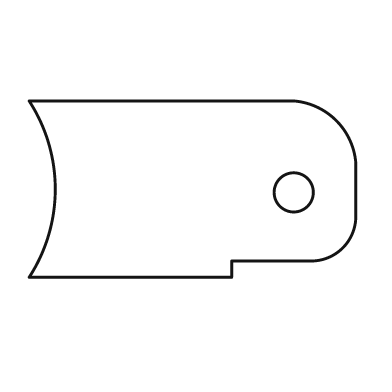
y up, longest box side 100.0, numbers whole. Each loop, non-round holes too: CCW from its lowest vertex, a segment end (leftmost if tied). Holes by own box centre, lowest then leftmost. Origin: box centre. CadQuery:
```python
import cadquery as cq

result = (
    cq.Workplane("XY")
    .moveTo(-50.0, -27.0)
    .lineTo(12.0, -27.0)
    .lineTo(12.0, -22.0)
    .lineTo(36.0, -22.0)
    .threePointArc((46.0, -18.0), (50.0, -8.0))
    .lineTo(50.0, 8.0)
    .threePointArc((44.0, 21.0), (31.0, 27.0))
    .lineTo(-50.0, 27.0)
    .threePointArc((-42.0, 0.0), (-50.0, -27.0))
    .close()
    .moveTo(31.0, -1.0)
    .circle(6.0)
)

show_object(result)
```